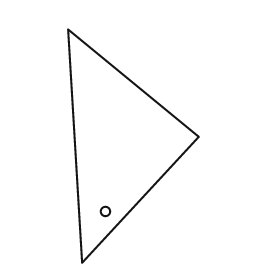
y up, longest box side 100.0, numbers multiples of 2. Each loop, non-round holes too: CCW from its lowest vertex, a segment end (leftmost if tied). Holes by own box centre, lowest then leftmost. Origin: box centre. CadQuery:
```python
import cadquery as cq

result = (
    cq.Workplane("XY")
    .moveTo(-22.0, -50.0)
    .lineTo(28.0, 4.0)
    .lineTo(-28.0, 50.0)
    .close()
    .moveTo(-12.0, -28.0)
    .circle(2.0)
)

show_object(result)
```